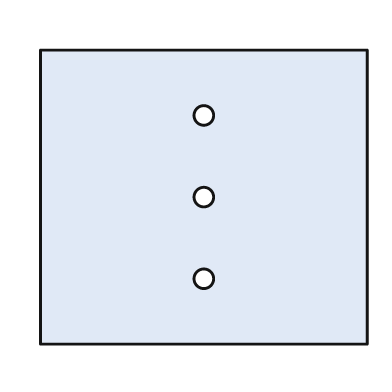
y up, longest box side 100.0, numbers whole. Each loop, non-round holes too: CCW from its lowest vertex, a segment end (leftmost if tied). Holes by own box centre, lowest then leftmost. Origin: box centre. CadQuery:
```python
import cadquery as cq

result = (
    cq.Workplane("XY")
    .moveTo(-50.0, -45.0)
    .lineTo(50.0, -45.0)
    .lineTo(50.0, 45.0)
    .lineTo(-50.0, 45.0)
    .close()
    .moveTo(0.0, -25.0)
    .circle(3.0)
    .moveTo(0.0, 0.0)
    .circle(3.0)
    .moveTo(0.0, 25.0)
    .circle(3.0)
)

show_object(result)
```